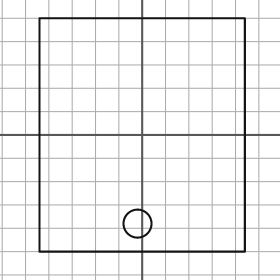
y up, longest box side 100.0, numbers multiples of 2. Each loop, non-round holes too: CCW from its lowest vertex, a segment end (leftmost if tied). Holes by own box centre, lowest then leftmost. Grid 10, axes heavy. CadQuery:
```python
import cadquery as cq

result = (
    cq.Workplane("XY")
    .moveTo(-44.0, -50.0)
    .lineTo(44.0, -50.0)
    .lineTo(44.0, 50.0)
    .lineTo(-44.0, 50.0)
    .close()
    .moveTo(-2.0, -38.0)
    .circle(6.0)
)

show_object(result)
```